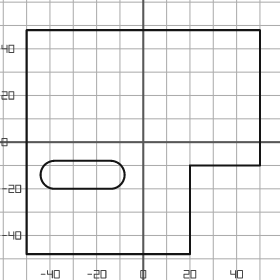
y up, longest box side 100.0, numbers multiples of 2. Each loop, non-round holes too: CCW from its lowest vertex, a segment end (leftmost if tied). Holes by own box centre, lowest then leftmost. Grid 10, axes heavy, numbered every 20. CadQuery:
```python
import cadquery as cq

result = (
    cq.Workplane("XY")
    .moveTo(-50.0, -48.0)
    .lineTo(20.0, -48.0)
    .lineTo(20.0, -10.0)
    .lineTo(50.0, -10.0)
    .lineTo(50.0, 48.0)
    .lineTo(-50.0, 48.0)
    .close()
    .moveTo(-38.0, -20.0)
    .lineTo(-14.0, -20.0)
    .threePointArc((-8.0, -14.0), (-14.0, -8.0))
    .lineTo(-38.0, -8.0)
    .threePointArc((-44.0, -14.0), (-38.0, -20.0))
    .close()
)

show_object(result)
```